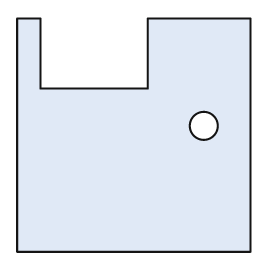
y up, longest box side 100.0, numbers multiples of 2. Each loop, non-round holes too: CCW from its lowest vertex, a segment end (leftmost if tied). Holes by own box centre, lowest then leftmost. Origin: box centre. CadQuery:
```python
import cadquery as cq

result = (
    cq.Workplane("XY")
    .moveTo(-50.0, -50.0)
    .lineTo(50.0, -50.0)
    .lineTo(50.0, 50.0)
    .lineTo(6.0, 50.0)
    .lineTo(6.0, 20.0)
    .lineTo(-40.0, 20.0)
    .lineTo(-40.0, 50.0)
    .lineTo(-50.0, 50.0)
    .close()
    .moveTo(30.0, 4.0)
    .circle(6.0)
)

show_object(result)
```